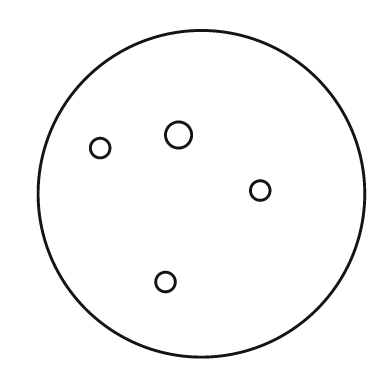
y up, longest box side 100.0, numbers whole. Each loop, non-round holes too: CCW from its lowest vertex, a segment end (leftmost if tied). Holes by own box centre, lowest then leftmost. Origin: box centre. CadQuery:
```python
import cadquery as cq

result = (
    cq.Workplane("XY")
    .moveTo(0.0, 0.0)
    .circle(50.0)
    .moveTo(-11.0, -27.0)
    .circle(3.0)
    .moveTo(18.0, 1.0)
    .circle(3.0)
    .moveTo(-31.0, 14.0)
    .circle(3.0)
    .moveTo(-7.0, 18.0)
    .circle(4.0)
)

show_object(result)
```